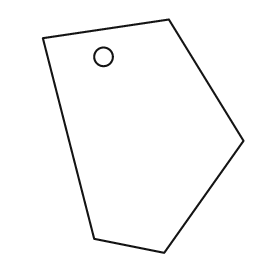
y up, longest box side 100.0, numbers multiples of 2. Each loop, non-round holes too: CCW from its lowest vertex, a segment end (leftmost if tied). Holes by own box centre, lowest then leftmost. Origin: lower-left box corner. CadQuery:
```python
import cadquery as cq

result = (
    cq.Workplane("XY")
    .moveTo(52.0, 0.0)
    .lineTo(86.0, 48.0)
    .lineTo(54.0, 100.0)
    .lineTo(0.0, 92.0)
    .lineTo(22.0, 6.0)
    .close()
    .moveTo(26.0, 84.0)
    .circle(4.0)
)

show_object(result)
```